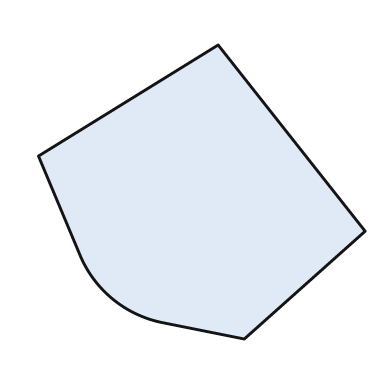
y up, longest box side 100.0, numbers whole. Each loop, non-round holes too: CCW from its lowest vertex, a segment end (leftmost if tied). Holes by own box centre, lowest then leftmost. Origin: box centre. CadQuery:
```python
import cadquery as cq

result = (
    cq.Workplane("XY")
    .moveTo(13.0, -45.0)
    .lineTo(50.0, -12.0)
    .lineTo(5.0, 45.0)
    .lineTo(-50.0, 11.0)
    .lineTo(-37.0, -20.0)
    .threePointArc((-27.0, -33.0), (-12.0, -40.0))
    .close()
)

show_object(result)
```